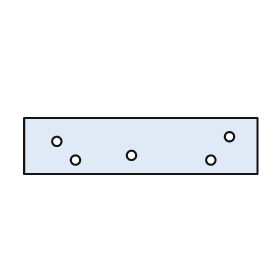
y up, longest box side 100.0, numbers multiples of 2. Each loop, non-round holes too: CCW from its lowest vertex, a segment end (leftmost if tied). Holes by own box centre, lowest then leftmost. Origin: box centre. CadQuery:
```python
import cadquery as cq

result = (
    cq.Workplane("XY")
    .moveTo(-50.0, -12.0)
    .lineTo(50.0, -12.0)
    .lineTo(50.0, 12.0)
    .lineTo(-50.0, 12.0)
    .close()
    .moveTo(-28.0, -6.0)
    .circle(2.0)
    .moveTo(30.0, -6.0)
    .circle(2.0)
    .moveTo(-4.0, -4.0)
    .circle(2.0)
    .moveTo(-36.0, 2.0)
    .circle(2.0)
    .moveTo(38.0, 4.0)
    .circle(2.0)
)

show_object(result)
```